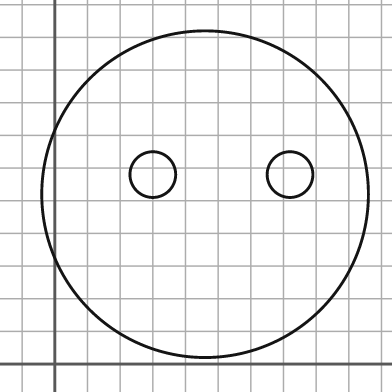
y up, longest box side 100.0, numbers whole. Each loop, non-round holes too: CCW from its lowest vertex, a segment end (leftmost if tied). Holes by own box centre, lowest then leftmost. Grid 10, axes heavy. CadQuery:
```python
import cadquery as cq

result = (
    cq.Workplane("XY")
    .moveTo(46.0, 52.0)
    .circle(50.0)
    .moveTo(30.0, 58.0)
    .circle(7.0)
    .moveTo(72.0, 58.0)
    .circle(7.0)
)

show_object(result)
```